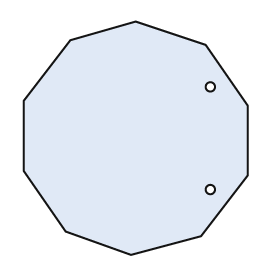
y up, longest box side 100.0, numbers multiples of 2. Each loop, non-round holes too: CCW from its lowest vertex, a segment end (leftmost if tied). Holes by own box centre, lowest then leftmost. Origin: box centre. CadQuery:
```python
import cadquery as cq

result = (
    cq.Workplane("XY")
    .moveTo(-2.0, -50.0)
    .lineTo(28.0, -42.0)
    .lineTo(48.0, -16.0)
    .lineTo(48.0, 14.0)
    .lineTo(30.0, 40.0)
    .lineTo(0.0, 50.0)
    .lineTo(-28.0, 42.0)
    .lineTo(-48.0, 16.0)
    .lineTo(-48.0, -14.0)
    .lineTo(-30.0, -40.0)
    .close()
    .moveTo(32.0, -22.0)
    .circle(2.0)
    .moveTo(32.0, 22.0)
    .circle(2.0)
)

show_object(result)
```